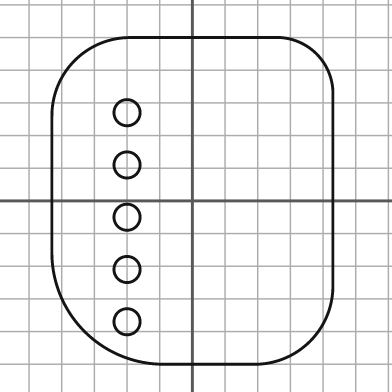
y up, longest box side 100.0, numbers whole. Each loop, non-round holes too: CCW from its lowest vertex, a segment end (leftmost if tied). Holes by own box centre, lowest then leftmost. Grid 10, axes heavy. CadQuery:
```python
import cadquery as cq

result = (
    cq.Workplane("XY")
    .moveTo(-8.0, -50.0)
    .lineTo(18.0, -50.0)
    .threePointArc((36.0, -43.0), (43.0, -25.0))
    .lineTo(43.0, 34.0)
    .threePointArc((38.0, 45.0), (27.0, 50.0))
    .lineTo(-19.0, 50.0)
    .threePointArc((-36.0, 43.0), (-43.0, 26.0))
    .lineTo(-43.0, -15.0)
    .threePointArc((-33.0, -40.0), (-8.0, -50.0))
    .close()
    .moveTo(-20.0, -37.0)
    .circle(4.0)
    .moveTo(-20.0, -21.0)
    .circle(4.0)
    .moveTo(-20.0, -5.0)
    .circle(4.0)
    .moveTo(-20.0, 11.0)
    .circle(4.0)
    .moveTo(-20.0, 27.0)
    .circle(4.0)
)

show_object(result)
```